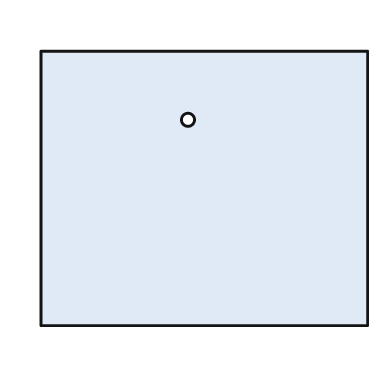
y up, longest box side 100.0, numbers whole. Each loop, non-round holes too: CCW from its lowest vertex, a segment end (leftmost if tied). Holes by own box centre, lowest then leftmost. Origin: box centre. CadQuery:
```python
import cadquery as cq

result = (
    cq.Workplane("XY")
    .moveTo(-50.0, -42.0)
    .lineTo(50.0, -42.0)
    .lineTo(50.0, 42.0)
    .lineTo(-50.0, 42.0)
    .close()
    .moveTo(-5.0, 21.0)
    .circle(2.0)
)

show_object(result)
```